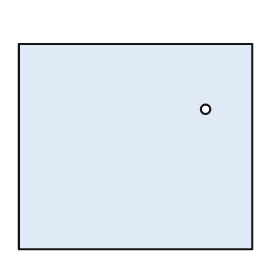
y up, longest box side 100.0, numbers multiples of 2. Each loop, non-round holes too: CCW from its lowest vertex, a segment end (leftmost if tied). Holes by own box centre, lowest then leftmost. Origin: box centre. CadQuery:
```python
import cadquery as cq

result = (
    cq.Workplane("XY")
    .moveTo(-50.0, -44.0)
    .lineTo(50.0, -44.0)
    .lineTo(50.0, 44.0)
    .lineTo(-50.0, 44.0)
    .close()
    .moveTo(30.0, 16.0)
    .circle(2.0)
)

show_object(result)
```